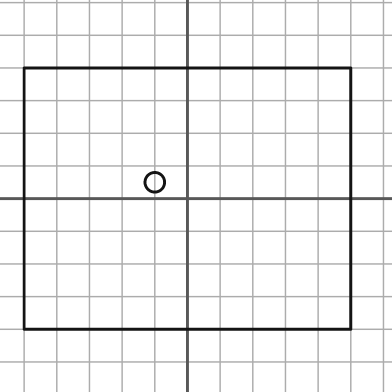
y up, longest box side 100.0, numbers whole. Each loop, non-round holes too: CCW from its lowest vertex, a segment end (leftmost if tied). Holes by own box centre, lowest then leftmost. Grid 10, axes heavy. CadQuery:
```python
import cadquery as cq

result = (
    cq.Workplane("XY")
    .moveTo(-50.0, -40.0)
    .lineTo(50.0, -40.0)
    .lineTo(50.0, 40.0)
    .lineTo(-50.0, 40.0)
    .close()
    .moveTo(-10.0, 5.0)
    .circle(3.0)
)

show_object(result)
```